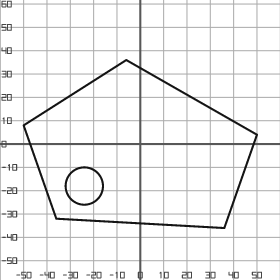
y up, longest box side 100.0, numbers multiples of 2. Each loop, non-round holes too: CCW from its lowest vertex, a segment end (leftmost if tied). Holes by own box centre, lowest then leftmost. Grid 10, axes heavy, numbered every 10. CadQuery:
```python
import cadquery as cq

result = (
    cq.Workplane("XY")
    .moveTo(36.0, -36.0)
    .lineTo(50.0, 4.0)
    .lineTo(-6.0, 36.0)
    .lineTo(-50.0, 8.0)
    .lineTo(-36.0, -32.0)
    .close()
    .moveTo(-24.0, -18.0)
    .circle(8.0)
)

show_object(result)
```